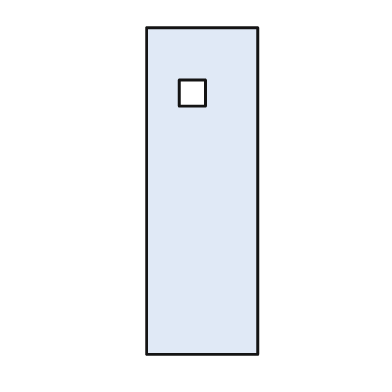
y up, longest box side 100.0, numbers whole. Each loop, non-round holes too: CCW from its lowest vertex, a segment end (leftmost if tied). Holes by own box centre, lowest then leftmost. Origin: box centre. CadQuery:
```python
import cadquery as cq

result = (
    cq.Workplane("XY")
    .moveTo(-17.0, -50.0)
    .lineTo(17.0, -50.0)
    .lineTo(17.0, 50.0)
    .lineTo(-17.0, 50.0)
    .close()
    .moveTo(-7.0, 26.0)
    .lineTo(1.0, 26.0)
    .lineTo(1.0, 34.0)
    .lineTo(-7.0, 34.0)
    .close()
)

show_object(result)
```